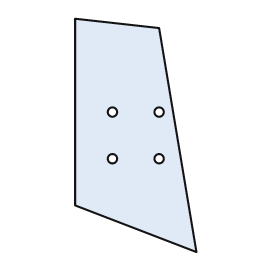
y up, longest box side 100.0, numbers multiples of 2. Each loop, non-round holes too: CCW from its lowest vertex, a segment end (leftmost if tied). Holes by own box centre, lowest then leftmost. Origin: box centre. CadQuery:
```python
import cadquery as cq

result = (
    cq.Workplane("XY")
    .moveTo(26.0, -50.0)
    .lineTo(10.0, 46.0)
    .lineTo(-26.0, 50.0)
    .lineTo(-26.0, -30.0)
    .close()
    .moveTo(-10.0, -10.0)
    .circle(2.0)
    .moveTo(10.0, -10.0)
    .circle(2.0)
    .moveTo(-10.0, 10.0)
    .circle(2.0)
    .moveTo(10.0, 10.0)
    .circle(2.0)
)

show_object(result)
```